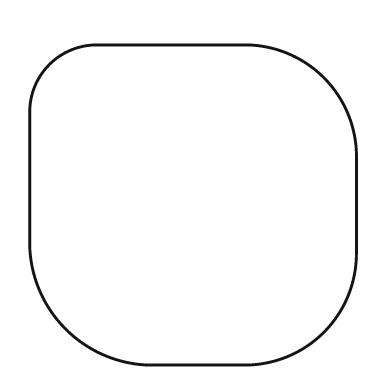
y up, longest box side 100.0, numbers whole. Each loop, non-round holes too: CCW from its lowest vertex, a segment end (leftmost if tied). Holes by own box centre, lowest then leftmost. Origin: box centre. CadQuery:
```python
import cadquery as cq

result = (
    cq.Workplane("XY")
    .moveTo(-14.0, -49.0)
    .lineTo(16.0, -49.0)
    .threePointArc((40.0, -39.0), (50.0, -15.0))
    .lineTo(50.0, 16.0)
    .threePointArc((40.0, 39.0), (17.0, 49.0))
    .lineTo(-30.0, 49.0)
    .threePointArc((-44.0, 43.0), (-50.0, 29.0))
    .lineTo(-50.0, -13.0)
    .threePointArc((-39.0, -38.0), (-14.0, -49.0))
    .close()
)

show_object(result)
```